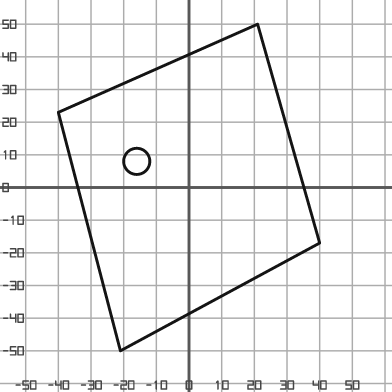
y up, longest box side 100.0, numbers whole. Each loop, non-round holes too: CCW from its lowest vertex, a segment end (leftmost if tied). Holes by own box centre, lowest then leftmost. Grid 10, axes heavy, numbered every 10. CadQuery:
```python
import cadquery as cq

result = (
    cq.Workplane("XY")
    .moveTo(-21.0, -50.0)
    .lineTo(40.0, -17.0)
    .lineTo(21.0, 50.0)
    .lineTo(-40.0, 23.0)
    .close()
    .moveTo(-16.0, 8.0)
    .circle(4.0)
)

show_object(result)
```